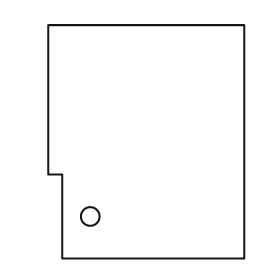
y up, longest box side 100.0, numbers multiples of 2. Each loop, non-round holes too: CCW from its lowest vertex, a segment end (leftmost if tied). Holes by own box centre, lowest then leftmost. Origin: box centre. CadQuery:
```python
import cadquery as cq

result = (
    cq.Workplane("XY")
    .moveTo(-36.0, -50.0)
    .lineTo(42.0, -50.0)
    .lineTo(42.0, 50.0)
    .lineTo(-42.0, 50.0)
    .lineTo(-42.0, -14.0)
    .lineTo(-36.0, -14.0)
    .close()
    .moveTo(-24.0, -32.0)
    .circle(4.0)
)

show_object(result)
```